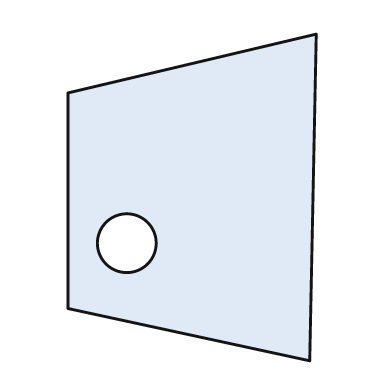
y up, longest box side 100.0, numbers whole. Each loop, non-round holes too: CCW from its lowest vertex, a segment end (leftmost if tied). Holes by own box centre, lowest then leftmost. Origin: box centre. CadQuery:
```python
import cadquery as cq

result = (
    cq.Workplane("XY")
    .moveTo(36.0, -50.0)
    .lineTo(38.0, 50.0)
    .lineTo(-38.0, 32.0)
    .lineTo(-38.0, -34.0)
    .close()
    .moveTo(-20.0, -14.0)
    .circle(9.0)
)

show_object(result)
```